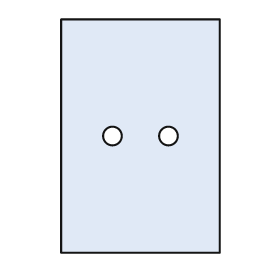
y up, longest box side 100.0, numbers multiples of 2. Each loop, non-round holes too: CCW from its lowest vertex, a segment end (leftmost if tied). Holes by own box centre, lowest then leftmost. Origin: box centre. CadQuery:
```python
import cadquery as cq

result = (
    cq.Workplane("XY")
    .moveTo(-34.0, -50.0)
    .lineTo(34.0, -50.0)
    .lineTo(34.0, 50.0)
    .lineTo(-34.0, 50.0)
    .close()
    .moveTo(-12.0, 0.0)
    .circle(4.0)
    .moveTo(12.0, 0.0)
    .circle(4.0)
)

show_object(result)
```